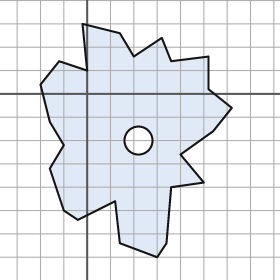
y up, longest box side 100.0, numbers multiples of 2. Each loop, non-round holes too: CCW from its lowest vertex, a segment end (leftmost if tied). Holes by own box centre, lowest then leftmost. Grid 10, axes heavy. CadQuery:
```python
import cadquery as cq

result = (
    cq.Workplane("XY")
    .moveTo(30.0, -70.0)
    .lineTo(34.0, -64.0)
    .lineTo(36.0, -40.0)
    .lineTo(50.0, -38.0)
    .lineTo(40.0, -26.0)
    .lineTo(54.0, -16.0)
    .lineTo(62.0, -6.0)
    .lineTo(52.0, 2.0)
    .lineTo(52.0, 16.0)
    .lineTo(36.0, 14.0)
    .lineTo(32.0, 24.0)
    .lineTo(20.0, 16.0)
    .lineTo(14.0, 26.0)
    .lineTo(-2.0, 30.0)
    .lineTo(0.0, 10.0)
    .lineTo(-12.0, 14.0)
    .lineTo(-20.0, 4.0)
    .lineTo(-16.0, -12.0)
    .lineTo(-10.0, -22.0)
    .lineTo(-16.0, -32.0)
    .lineTo(-10.0, -50.0)
    .lineTo(-4.0, -54.0)
    .lineTo(12.0, -46.0)
    .lineTo(14.0, -64.0)
    .close()
    .moveTo(22.0, -20.0)
    .circle(6.0)
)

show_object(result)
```